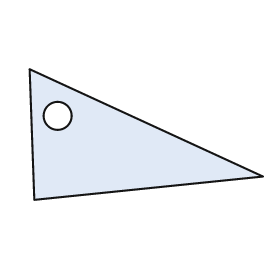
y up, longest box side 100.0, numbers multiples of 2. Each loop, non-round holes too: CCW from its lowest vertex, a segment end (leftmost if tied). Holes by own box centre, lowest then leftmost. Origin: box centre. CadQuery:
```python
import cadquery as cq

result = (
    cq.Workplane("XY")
    .moveTo(-48.0, -28.0)
    .lineTo(50.0, -18.0)
    .lineTo(-50.0, 28.0)
    .close()
    .moveTo(-38.0, 8.0)
    .circle(6.0)
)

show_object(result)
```